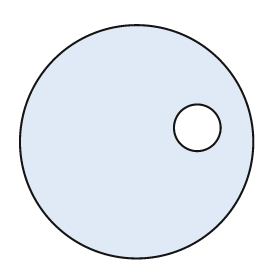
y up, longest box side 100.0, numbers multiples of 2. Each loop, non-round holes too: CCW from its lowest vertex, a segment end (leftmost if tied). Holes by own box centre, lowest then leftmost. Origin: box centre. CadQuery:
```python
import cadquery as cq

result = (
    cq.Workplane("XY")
    .moveTo(0.0, 0.0)
    .circle(50.0)
    .moveTo(26.0, 6.0)
    .circle(10.0)
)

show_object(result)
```